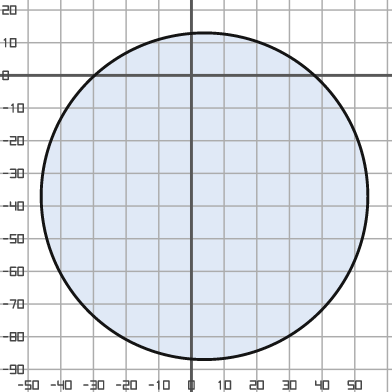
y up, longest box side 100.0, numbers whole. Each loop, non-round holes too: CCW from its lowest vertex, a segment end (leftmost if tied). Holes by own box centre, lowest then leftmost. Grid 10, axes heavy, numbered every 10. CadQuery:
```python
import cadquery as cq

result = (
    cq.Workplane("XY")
    .moveTo(4.0, -37.0)
    .circle(50.0)
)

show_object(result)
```